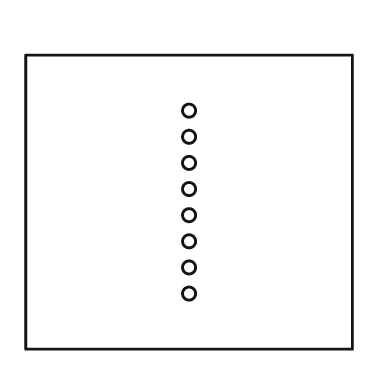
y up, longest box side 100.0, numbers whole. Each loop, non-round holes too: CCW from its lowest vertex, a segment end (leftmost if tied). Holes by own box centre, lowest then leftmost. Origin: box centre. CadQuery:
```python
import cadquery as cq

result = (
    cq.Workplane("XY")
    .moveTo(-50.0, -45.0)
    .lineTo(50.0, -45.0)
    .lineTo(50.0, 45.0)
    .lineTo(-50.0, 45.0)
    .close()
    .moveTo(0.0, -28.0)
    .circle(2.0)
    .moveTo(0.0, -20.0)
    .circle(2.0)
    .moveTo(0.0, -12.0)
    .circle(2.0)
    .moveTo(0.0, -4.0)
    .circle(2.0)
    .moveTo(0.0, 4.0)
    .circle(2.0)
    .moveTo(0.0, 12.0)
    .circle(2.0)
    .moveTo(0.0, 20.0)
    .circle(2.0)
    .moveTo(0.0, 28.0)
    .circle(2.0)
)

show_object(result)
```